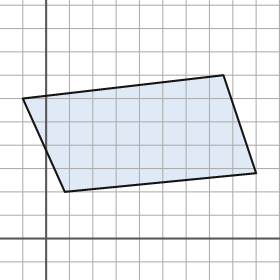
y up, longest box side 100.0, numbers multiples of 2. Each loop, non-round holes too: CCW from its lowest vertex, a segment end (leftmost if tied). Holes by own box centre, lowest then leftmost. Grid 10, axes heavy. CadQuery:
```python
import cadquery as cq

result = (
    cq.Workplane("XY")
    .moveTo(8.0, 20.0)
    .lineTo(90.0, 28.0)
    .lineTo(76.0, 70.0)
    .lineTo(-10.0, 60.0)
    .close()
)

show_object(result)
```